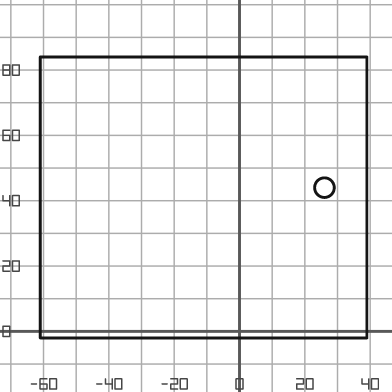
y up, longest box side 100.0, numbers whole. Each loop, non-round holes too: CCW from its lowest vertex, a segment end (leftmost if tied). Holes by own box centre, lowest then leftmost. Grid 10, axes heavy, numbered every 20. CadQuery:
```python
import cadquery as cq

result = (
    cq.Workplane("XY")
    .moveTo(-61.0, -2.0)
    .lineTo(39.0, -2.0)
    .lineTo(39.0, 84.0)
    .lineTo(-61.0, 84.0)
    .close()
    .moveTo(26.0, 44.0)
    .circle(3.0)
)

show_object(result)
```